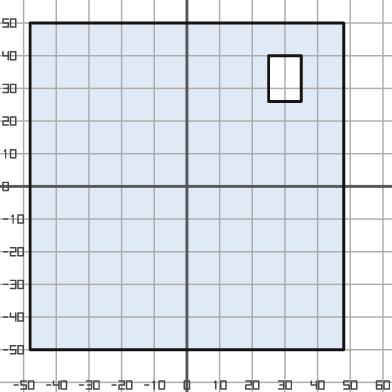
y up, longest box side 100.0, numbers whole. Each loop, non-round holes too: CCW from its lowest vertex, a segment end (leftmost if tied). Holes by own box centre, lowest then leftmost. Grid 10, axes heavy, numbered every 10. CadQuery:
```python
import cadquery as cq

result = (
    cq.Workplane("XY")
    .moveTo(-48.0, -50.0)
    .lineTo(48.0, -50.0)
    .lineTo(48.0, 50.0)
    .lineTo(-48.0, 50.0)
    .close()
    .moveTo(25.0, 26.0)
    .lineTo(35.0, 26.0)
    .lineTo(35.0, 40.0)
    .lineTo(25.0, 40.0)
    .close()
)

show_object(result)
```